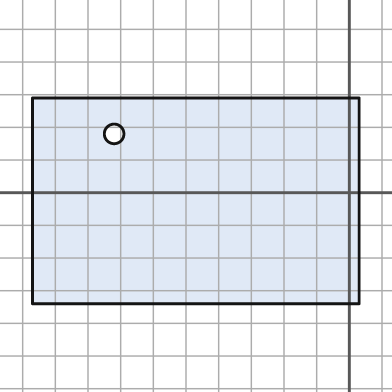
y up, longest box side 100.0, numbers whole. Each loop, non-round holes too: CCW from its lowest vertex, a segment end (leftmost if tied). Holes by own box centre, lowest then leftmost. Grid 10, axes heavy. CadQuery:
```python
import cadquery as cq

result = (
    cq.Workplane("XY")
    .moveTo(-97.0, -34.0)
    .lineTo(3.0, -34.0)
    .lineTo(3.0, 29.0)
    .lineTo(-97.0, 29.0)
    .close()
    .moveTo(-72.0, 18.0)
    .circle(3.0)
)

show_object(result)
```